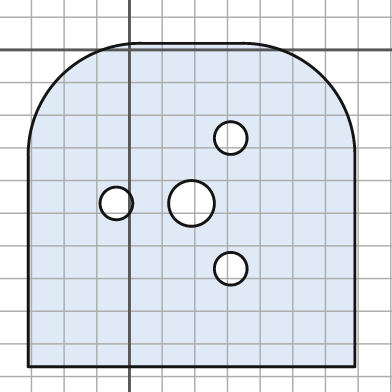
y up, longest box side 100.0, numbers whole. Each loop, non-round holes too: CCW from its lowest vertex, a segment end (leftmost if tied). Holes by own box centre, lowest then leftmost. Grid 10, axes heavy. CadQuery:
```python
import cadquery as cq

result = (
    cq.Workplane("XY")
    .moveTo(-31.0, -97.0)
    .lineTo(69.0, -97.0)
    .lineTo(69.0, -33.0)
    .threePointArc((59.0, -8.0), (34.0, 2.0))
    .lineTo(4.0, 2.0)
    .threePointArc((-21.0, -8.0), (-31.0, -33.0))
    .close()
    .moveTo(31.0, -67.0)
    .circle(5.0)
    .moveTo(-4.0, -47.0)
    .circle(5.0)
    .moveTo(19.0, -47.0)
    .circle(7.0)
    .moveTo(31.0, -27.0)
    .circle(5.0)
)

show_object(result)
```